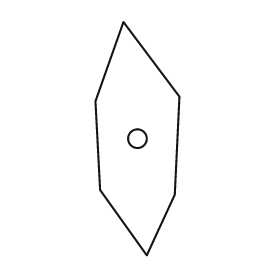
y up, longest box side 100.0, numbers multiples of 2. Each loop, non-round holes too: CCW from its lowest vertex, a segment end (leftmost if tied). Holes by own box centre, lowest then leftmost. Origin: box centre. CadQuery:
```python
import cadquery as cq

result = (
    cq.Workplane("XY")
    .moveTo(4.0, -50.0)
    .lineTo(16.0, -24.0)
    .lineTo(18.0, 18.0)
    .lineTo(-6.0, 50.0)
    .lineTo(-18.0, 16.0)
    .lineTo(-16.0, -22.0)
    .close()
    .moveTo(0.0, 0.0)
    .circle(4.0)
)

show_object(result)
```